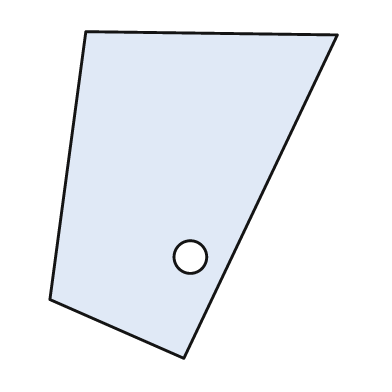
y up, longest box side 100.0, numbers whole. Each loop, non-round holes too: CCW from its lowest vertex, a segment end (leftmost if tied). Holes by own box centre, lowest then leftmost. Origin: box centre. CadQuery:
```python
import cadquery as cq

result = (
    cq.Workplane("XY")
    .moveTo(-3.0, -50.0)
    .lineTo(44.0, 49.0)
    .lineTo(-33.0, 50.0)
    .lineTo(-44.0, -32.0)
    .close()
    .moveTo(-1.0, -19.0)
    .circle(5.0)
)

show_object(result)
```